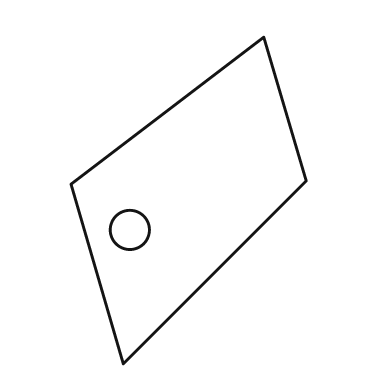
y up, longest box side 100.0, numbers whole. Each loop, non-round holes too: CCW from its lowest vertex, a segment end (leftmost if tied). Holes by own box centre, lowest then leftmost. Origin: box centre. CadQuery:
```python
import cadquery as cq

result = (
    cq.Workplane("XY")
    .moveTo(-20.0, -50.0)
    .lineTo(36.0, 6.0)
    .lineTo(23.0, 50.0)
    .lineTo(-36.0, 5.0)
    .close()
    .moveTo(-18.0, -9.0)
    .circle(6.0)
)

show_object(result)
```